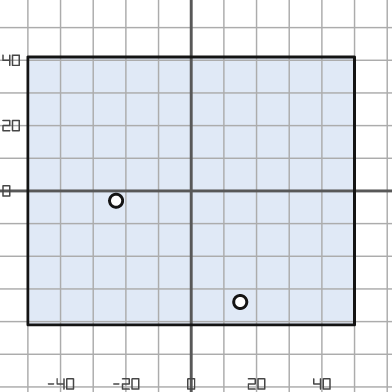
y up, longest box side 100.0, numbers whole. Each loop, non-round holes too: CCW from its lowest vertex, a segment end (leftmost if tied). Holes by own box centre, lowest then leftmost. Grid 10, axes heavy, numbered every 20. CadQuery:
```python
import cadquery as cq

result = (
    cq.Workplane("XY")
    .moveTo(-50.0, -41.0)
    .lineTo(50.0, -41.0)
    .lineTo(50.0, 41.0)
    .lineTo(-50.0, 41.0)
    .close()
    .moveTo(15.0, -34.0)
    .circle(2.0)
    .moveTo(-23.0, -3.0)
    .circle(2.0)
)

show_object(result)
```